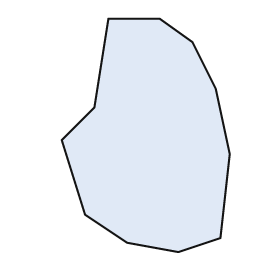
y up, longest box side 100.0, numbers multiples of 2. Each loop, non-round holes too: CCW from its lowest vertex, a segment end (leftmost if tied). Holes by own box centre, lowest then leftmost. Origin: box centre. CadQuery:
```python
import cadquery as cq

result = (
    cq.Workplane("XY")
    .moveTo(14.0, -50.0)
    .lineTo(32.0, -44.0)
    .lineTo(36.0, -8.0)
    .lineTo(30.0, 20.0)
    .lineTo(20.0, 40.0)
    .lineTo(6.0, 50.0)
    .lineTo(-16.0, 50.0)
    .lineTo(-22.0, 12.0)
    .lineTo(-36.0, -2.0)
    .lineTo(-26.0, -34.0)
    .lineTo(-8.0, -46.0)
    .close()
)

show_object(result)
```